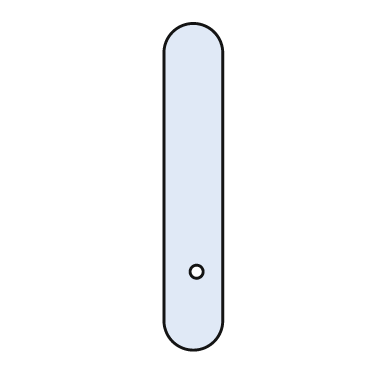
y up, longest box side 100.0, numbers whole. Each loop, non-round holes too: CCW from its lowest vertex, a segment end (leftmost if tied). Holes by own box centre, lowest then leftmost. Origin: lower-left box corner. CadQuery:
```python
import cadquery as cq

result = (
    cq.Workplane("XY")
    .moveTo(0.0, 9.0)
    .threePointArc((9.0, 0.0), (18.0, 9.0))
    .lineTo(18.0, 91.0)
    .threePointArc((9.0, 100.0), (0.0, 91.0))
    .close()
    .moveTo(10.0, 24.0)
    .circle(2.0)
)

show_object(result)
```